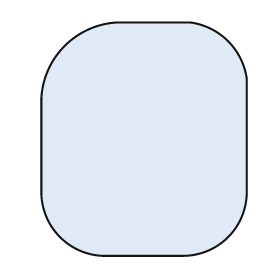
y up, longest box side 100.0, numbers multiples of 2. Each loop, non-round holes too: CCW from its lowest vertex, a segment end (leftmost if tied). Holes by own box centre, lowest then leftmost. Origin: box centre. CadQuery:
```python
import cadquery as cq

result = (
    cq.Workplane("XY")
    .moveTo(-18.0, -50.0)
    .lineTo(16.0, -50.0)
    .threePointArc((36.0, -42.0), (44.0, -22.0))
    .lineTo(44.0, 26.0)
    .threePointArc((36.0, 42.0), (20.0, 50.0))
    .lineTo(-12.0, 50.0)
    .threePointArc((-34.0, 40.0), (-44.0, 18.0))
    .lineTo(-44.0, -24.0)
    .threePointArc((-36.0, -42.0), (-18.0, -50.0))
    .close()
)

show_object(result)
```